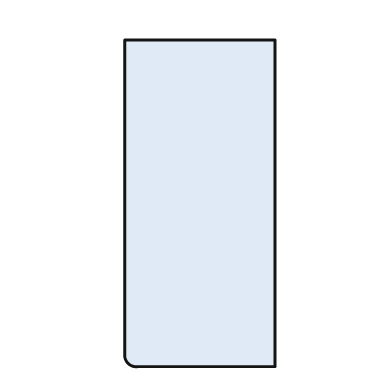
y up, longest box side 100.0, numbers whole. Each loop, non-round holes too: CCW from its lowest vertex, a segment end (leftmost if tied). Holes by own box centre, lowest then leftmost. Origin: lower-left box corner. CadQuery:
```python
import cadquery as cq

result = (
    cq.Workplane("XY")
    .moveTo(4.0, 0.0)
    .lineTo(46.0, 0.0)
    .lineTo(46.0, 100.0)
    .lineTo(0.0, 100.0)
    .lineTo(0.0, 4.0)
    .threePointArc((1.0, 1.0), (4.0, 0.0))
    .close()
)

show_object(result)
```